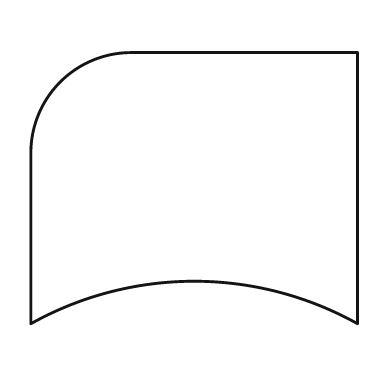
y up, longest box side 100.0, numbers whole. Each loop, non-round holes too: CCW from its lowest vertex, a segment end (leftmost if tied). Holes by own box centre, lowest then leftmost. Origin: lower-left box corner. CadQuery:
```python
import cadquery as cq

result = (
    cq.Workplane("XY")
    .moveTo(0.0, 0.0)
    .threePointArc((50.0, 13.0), (100.0, 0.0))
    .lineTo(100.0, 83.0)
    .lineTo(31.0, 83.0)
    .threePointArc((9.0, 74.0), (0.0, 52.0))
    .close()
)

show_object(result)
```